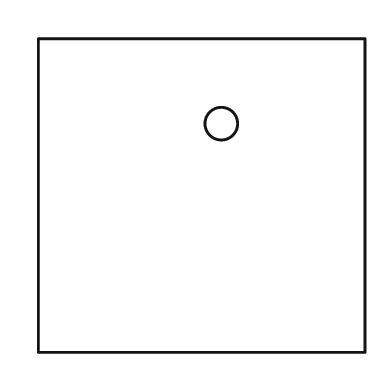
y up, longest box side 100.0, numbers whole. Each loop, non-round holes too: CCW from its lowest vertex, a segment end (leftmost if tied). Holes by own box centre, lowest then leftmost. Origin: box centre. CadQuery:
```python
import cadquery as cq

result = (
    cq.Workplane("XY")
    .moveTo(-50.0, -48.0)
    .lineTo(50.0, -48.0)
    .lineTo(50.0, 48.0)
    .lineTo(-50.0, 48.0)
    .close()
    .moveTo(6.0, 22.0)
    .circle(5.0)
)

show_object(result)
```